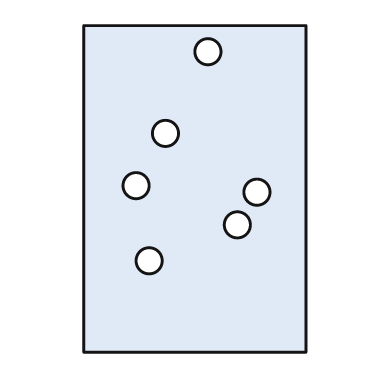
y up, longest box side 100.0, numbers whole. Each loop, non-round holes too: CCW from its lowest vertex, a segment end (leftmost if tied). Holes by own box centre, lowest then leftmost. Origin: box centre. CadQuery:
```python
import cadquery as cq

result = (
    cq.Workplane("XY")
    .moveTo(-34.0, -50.0)
    .lineTo(34.0, -50.0)
    .lineTo(34.0, 50.0)
    .lineTo(-34.0, 50.0)
    .close()
    .moveTo(-14.0, -22.0)
    .circle(4.0)
    .moveTo(13.0, -11.0)
    .circle(4.0)
    .moveTo(19.0, -1.0)
    .circle(4.0)
    .moveTo(-18.0, 1.0)
    .circle(4.0)
    .moveTo(-9.0, 17.0)
    .circle(4.0)
    .moveTo(4.0, 42.0)
    .circle(4.0)
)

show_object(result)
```